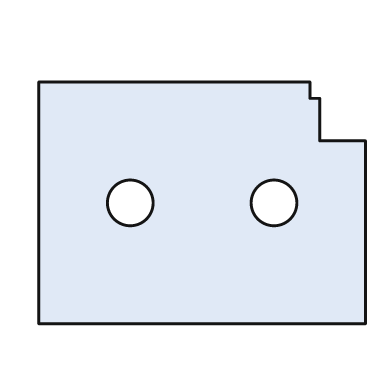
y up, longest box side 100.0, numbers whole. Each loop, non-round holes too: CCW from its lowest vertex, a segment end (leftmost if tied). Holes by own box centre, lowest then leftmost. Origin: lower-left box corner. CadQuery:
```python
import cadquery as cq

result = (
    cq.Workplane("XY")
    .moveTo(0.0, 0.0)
    .lineTo(100.0, 0.0)
    .lineTo(100.0, 56.0)
    .lineTo(86.0, 56.0)
    .lineTo(86.0, 69.0)
    .lineTo(83.0, 69.0)
    .lineTo(83.0, 74.0)
    .lineTo(0.0, 74.0)
    .close()
    .moveTo(28.0, 37.0)
    .circle(7.0)
    .moveTo(72.0, 37.0)
    .circle(7.0)
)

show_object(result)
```